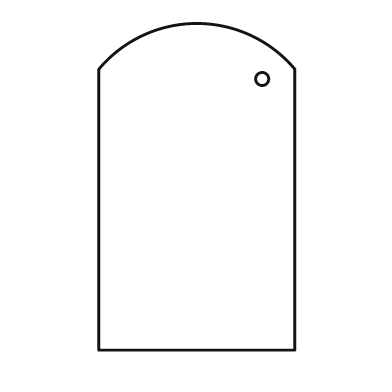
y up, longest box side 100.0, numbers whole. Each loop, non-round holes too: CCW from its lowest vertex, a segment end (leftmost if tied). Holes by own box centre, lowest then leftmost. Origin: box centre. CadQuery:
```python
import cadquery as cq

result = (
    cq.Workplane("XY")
    .moveTo(-30.0, -50.0)
    .lineTo(30.0, -50.0)
    .lineTo(30.0, 36.0)
    .threePointArc((0.0, 50.0), (-30.0, 36.0))
    .close()
    .moveTo(20.0, 33.0)
    .circle(2.0)
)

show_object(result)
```